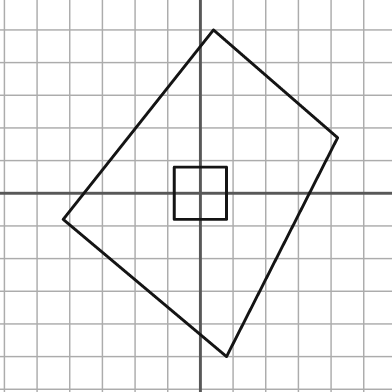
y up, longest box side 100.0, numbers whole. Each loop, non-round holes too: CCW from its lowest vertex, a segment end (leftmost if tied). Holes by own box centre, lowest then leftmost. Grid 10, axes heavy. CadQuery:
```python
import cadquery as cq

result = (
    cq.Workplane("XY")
    .moveTo(8.0, -50.0)
    .lineTo(42.0, 17.0)
    .lineTo(4.0, 50.0)
    .lineTo(-42.0, -8.0)
    .close()
    .moveTo(-8.0, -8.0)
    .lineTo(8.0, -8.0)
    .lineTo(8.0, 8.0)
    .lineTo(-8.0, 8.0)
    .close()
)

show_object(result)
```